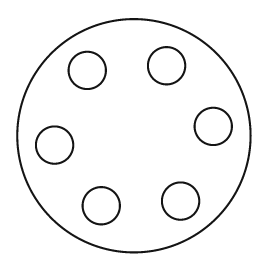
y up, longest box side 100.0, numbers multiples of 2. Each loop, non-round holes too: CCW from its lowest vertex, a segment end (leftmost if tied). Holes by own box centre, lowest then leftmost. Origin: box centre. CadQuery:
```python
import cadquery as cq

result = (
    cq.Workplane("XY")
    .moveTo(0.0, 0.0)
    .circle(50.0)
    .moveTo(-14.0, -30.0)
    .circle(8.0)
    .moveTo(20.0, -28.0)
    .circle(8.0)
    .moveTo(-34.0, -4.0)
    .circle(8.0)
    .moveTo(34.0, 4.0)
    .circle(8.0)
    .moveTo(-20.0, 28.0)
    .circle(8.0)
    .moveTo(14.0, 30.0)
    .circle(8.0)
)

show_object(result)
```